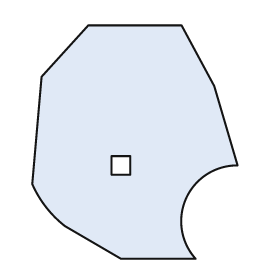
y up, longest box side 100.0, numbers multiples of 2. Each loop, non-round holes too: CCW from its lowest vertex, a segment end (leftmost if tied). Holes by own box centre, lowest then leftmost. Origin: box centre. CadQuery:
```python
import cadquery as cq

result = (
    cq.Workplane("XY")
    .moveTo(-6.0, -50.0)
    .lineTo(26.0, -50.0)
    .threePointArc((22.0, -24.0), (44.0, -10.0))
    .lineTo(34.0, 24.0)
    .lineTo(20.0, 50.0)
    .lineTo(-20.0, 50.0)
    .lineTo(-40.0, 28.0)
    .lineTo(-44.0, -18.0)
    .threePointArc((-38.0, -28.0), (-30.0, -36.0))
    .close()
    .moveTo(-10.0, -14.0)
    .lineTo(-2.0, -14.0)
    .lineTo(-2.0, -6.0)
    .lineTo(-10.0, -6.0)
    .close()
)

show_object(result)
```